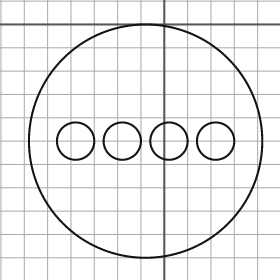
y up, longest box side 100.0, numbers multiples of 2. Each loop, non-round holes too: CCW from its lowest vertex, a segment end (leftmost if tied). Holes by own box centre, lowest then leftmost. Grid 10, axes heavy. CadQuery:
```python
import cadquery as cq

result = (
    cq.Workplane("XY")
    .moveTo(-8.0, -50.0)
    .circle(50.0)
    .moveTo(-38.0, -50.0)
    .circle(8.0)
    .moveTo(-18.0, -50.0)
    .circle(8.0)
    .moveTo(2.0, -50.0)
    .circle(8.0)
    .moveTo(22.0, -50.0)
    .circle(8.0)
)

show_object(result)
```